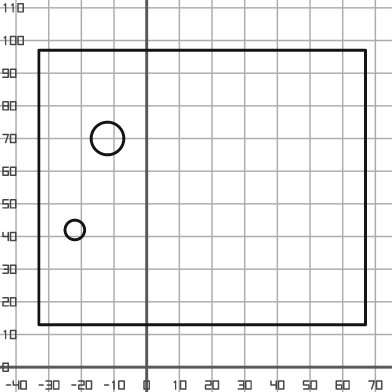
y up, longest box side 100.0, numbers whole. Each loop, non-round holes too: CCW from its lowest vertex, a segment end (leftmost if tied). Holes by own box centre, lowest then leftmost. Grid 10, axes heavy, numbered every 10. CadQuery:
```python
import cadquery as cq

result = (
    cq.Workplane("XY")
    .moveTo(-33.0, 13.0)
    .lineTo(67.0, 13.0)
    .lineTo(67.0, 97.0)
    .lineTo(-33.0, 97.0)
    .close()
    .moveTo(-22.0, 42.0)
    .circle(3.0)
    .moveTo(-12.0, 70.0)
    .circle(5.0)
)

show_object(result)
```